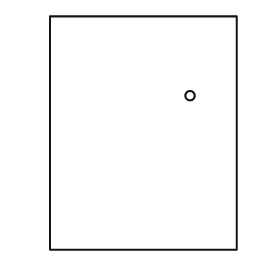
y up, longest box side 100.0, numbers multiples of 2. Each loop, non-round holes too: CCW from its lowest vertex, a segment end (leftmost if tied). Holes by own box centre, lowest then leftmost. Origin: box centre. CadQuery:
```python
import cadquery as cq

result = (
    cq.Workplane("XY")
    .moveTo(-40.0, -50.0)
    .lineTo(40.0, -50.0)
    .lineTo(40.0, 50.0)
    .lineTo(-40.0, 50.0)
    .close()
    .moveTo(20.0, 16.0)
    .circle(2.0)
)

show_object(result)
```